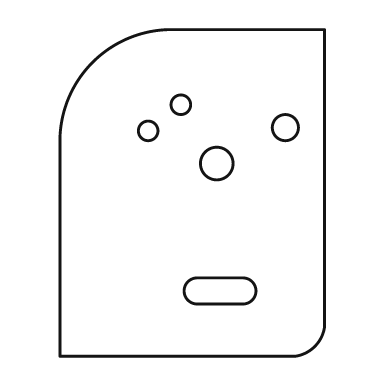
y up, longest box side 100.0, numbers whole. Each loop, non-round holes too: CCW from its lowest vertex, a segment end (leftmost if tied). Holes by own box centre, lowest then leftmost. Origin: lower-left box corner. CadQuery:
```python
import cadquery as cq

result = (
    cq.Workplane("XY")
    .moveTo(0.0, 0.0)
    .lineTo(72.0, 0.0)
    .threePointArc((78.0, 3.0), (81.0, 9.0))
    .lineTo(81.0, 100.0)
    .lineTo(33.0, 100.0)
    .threePointArc((10.0, 90.0), (0.0, 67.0))
    .close()
    .moveTo(42.0, 16.0)
    .lineTo(56.0, 16.0)
    .threePointArc((60.0, 20.0), (56.0, 24.0))
    .lineTo(42.0, 24.0)
    .threePointArc((38.0, 20.0), (42.0, 16.0))
    .close()
    .moveTo(48.0, 59.0)
    .circle(5.0)
    .moveTo(27.0, 69.0)
    .circle(3.0)
    .moveTo(69.0, 70.0)
    .circle(4.0)
    .moveTo(37.0, 77.0)
    .circle(3.0)
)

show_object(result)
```